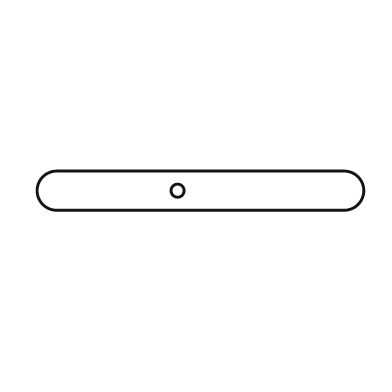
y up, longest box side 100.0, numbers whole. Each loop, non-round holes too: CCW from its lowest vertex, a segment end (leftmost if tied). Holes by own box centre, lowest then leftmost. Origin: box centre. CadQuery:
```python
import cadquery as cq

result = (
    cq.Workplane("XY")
    .moveTo(-44.0, -6.0)
    .lineTo(44.0, -6.0)
    .threePointArc((50.0, 0.0), (44.0, 6.0))
    .lineTo(-44.0, 6.0)
    .threePointArc((-50.0, 0.0), (-44.0, -6.0))
    .close()
    .moveTo(-7.0, 0.0)
    .circle(2.0)
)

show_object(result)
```